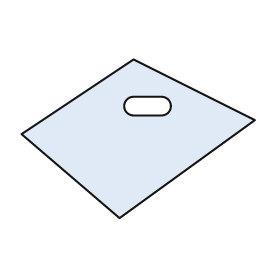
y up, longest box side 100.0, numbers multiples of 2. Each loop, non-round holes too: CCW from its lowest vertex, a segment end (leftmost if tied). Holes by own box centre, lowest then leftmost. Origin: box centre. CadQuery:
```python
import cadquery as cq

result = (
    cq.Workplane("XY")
    .moveTo(-8.0, -34.0)
    .lineTo(50.0, 8.0)
    .lineTo(-2.0, 34.0)
    .lineTo(-50.0, 2.0)
    .close()
    .moveTo(-2.0, 10.0)
    .lineTo(10.0, 10.0)
    .threePointArc((14.0, 14.0), (10.0, 18.0))
    .lineTo(-2.0, 18.0)
    .threePointArc((-6.0, 14.0), (-2.0, 10.0))
    .close()
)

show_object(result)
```